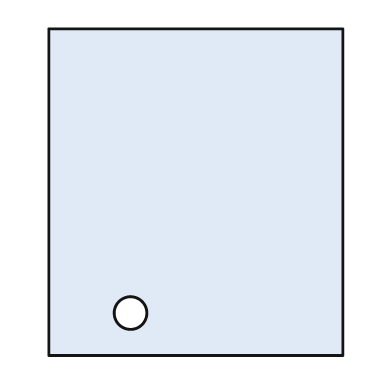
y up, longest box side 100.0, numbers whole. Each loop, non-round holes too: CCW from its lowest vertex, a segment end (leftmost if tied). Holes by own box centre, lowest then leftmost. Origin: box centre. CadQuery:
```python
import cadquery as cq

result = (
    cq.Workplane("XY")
    .moveTo(-45.0, -50.0)
    .lineTo(45.0, -50.0)
    .lineTo(45.0, 50.0)
    .lineTo(-45.0, 50.0)
    .close()
    .moveTo(-20.0, -37.0)
    .circle(5.0)
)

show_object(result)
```